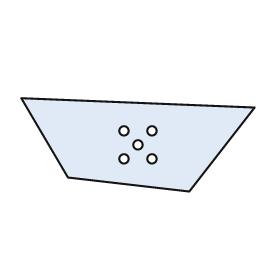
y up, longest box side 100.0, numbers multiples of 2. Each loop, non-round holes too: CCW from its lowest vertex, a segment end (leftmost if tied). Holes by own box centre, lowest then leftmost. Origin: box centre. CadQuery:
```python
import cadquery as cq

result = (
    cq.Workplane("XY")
    .moveTo(22.0, -20.0)
    .lineTo(50.0, 16.0)
    .lineTo(-50.0, 20.0)
    .lineTo(-30.0, -14.0)
    .close()
    .moveTo(-6.0, -6.0)
    .circle(2.0)
    .moveTo(6.0, -6.0)
    .circle(2.0)
    .moveTo(0.0, 0.0)
    .circle(2.0)
    .moveTo(-6.0, 6.0)
    .circle(2.0)
    .moveTo(6.0, 6.0)
    .circle(2.0)
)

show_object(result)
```